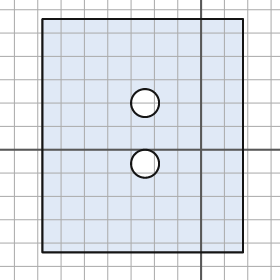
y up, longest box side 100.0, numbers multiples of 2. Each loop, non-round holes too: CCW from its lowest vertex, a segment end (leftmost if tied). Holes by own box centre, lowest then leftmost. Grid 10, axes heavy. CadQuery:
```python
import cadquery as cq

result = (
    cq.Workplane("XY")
    .moveTo(-68.0, -44.0)
    .lineTo(18.0, -44.0)
    .lineTo(18.0, 56.0)
    .lineTo(-68.0, 56.0)
    .close()
    .moveTo(-24.0, -6.0)
    .circle(6.0)
    .moveTo(-24.0, 20.0)
    .circle(6.0)
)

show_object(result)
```